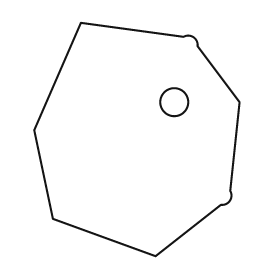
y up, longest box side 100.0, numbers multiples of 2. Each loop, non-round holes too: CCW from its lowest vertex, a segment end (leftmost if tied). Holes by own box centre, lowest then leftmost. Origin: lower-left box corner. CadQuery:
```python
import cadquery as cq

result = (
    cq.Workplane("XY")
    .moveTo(52.0, 0.0)
    .lineTo(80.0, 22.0)
    .threePointArc((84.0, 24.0), (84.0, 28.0))
    .lineTo(88.0, 66.0)
    .lineTo(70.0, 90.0)
    .threePointArc((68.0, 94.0), (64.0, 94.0))
    .lineTo(20.0, 100.0)
    .lineTo(0.0, 54.0)
    .lineTo(8.0, 16.0)
    .close()
    .moveTo(60.0, 66.0)
    .circle(6.0)
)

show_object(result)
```